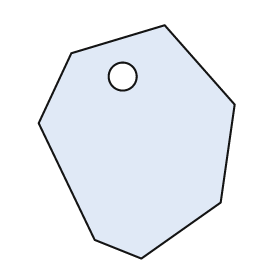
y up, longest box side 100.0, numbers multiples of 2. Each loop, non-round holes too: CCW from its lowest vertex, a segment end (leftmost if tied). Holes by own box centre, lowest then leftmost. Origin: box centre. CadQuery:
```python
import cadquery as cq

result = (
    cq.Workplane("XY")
    .moveTo(2.0, -50.0)
    .lineTo(36.0, -26.0)
    .lineTo(42.0, 16.0)
    .lineTo(12.0, 50.0)
    .lineTo(-28.0, 38.0)
    .lineTo(-42.0, 8.0)
    .lineTo(-18.0, -42.0)
    .close()
    .moveTo(-6.0, 28.0)
    .circle(6.0)
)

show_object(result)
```